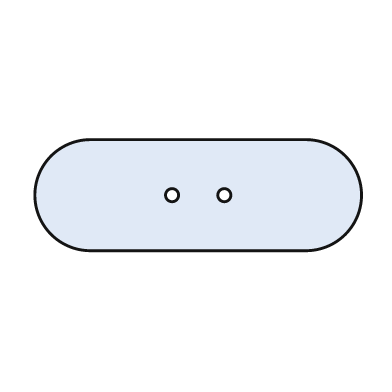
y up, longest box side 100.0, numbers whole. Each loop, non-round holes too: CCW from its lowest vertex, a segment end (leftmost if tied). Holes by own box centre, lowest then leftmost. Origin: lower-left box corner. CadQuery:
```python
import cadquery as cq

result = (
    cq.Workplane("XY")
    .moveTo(17.0, 0.0)
    .lineTo(83.0, 0.0)
    .threePointArc((100.0, 17.0), (83.0, 34.0))
    .lineTo(17.0, 34.0)
    .threePointArc((0.0, 17.0), (17.0, 0.0))
    .close()
    .moveTo(42.0, 17.0)
    .circle(2.0)
    .moveTo(58.0, 17.0)
    .circle(2.0)
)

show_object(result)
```